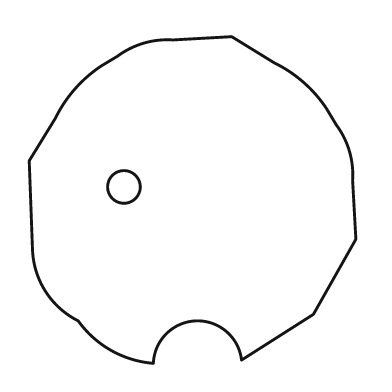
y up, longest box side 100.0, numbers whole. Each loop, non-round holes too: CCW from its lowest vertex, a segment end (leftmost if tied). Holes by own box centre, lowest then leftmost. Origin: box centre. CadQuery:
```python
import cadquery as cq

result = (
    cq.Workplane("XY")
    .moveTo(-12.0, -50.0)
    .threePointArc((1.0, -37.0), (15.0, -49.0))
    .lineTo(37.0, -35.0)
    .lineTo(50.0, -12.0)
    .lineTo(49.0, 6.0)
    .threePointArc((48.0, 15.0), (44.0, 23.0))
    .lineTo(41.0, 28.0)
    .threePointArc((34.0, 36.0), (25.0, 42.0))
    .lineTo(12.0, 50.0)
    .lineTo(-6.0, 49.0)
    .threePointArc((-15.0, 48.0), (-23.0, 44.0))
    .lineTo(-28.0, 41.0)
    .threePointArc((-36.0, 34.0), (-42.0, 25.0))
    .lineTo(-50.0, 12.0)
    .lineTo(-49.0, -15.0)
    .threePointArc((-45.0, -28.0), (-35.0, -37.0))
    .threePointArc((-25.0, -46.0), (-12.0, -50.0))
    .close()
    .moveTo(-21.0, 4.0)
    .circle(5.0)
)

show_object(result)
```